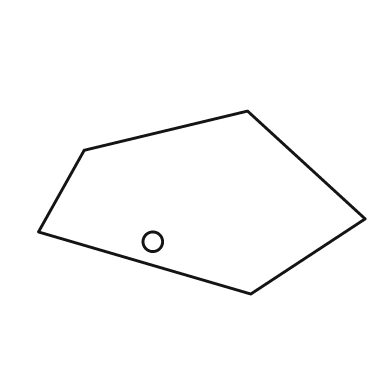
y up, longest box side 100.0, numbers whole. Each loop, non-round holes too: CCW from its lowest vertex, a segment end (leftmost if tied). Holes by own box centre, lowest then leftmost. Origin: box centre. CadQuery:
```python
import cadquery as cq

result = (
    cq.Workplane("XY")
    .moveTo(15.0, -28.0)
    .lineTo(50.0, -5.0)
    .lineTo(14.0, 28.0)
    .lineTo(-36.0, 16.0)
    .lineTo(-50.0, -9.0)
    .close()
    .moveTo(-15.0, -12.0)
    .circle(3.0)
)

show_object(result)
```